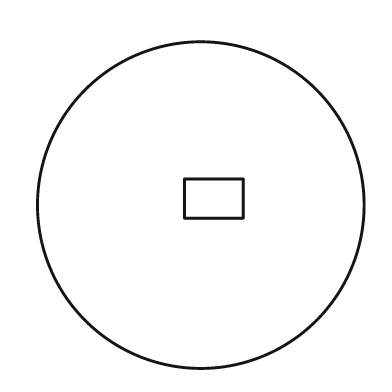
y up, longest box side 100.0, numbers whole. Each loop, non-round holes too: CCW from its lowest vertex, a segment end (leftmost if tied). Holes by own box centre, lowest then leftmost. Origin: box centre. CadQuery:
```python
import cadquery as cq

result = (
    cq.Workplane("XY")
    .moveTo(0.0, 0.0)
    .circle(50.0)
    .moveTo(-5.0, -4.0)
    .lineTo(13.0, -4.0)
    .lineTo(13.0, 8.0)
    .lineTo(-5.0, 8.0)
    .close()
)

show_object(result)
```